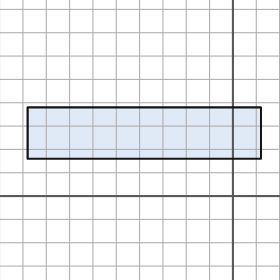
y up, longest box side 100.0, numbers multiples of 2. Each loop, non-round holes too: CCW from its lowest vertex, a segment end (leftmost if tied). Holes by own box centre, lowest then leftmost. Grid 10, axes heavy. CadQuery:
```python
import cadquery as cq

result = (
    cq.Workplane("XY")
    .moveTo(-88.0, 16.0)
    .lineTo(12.0, 16.0)
    .lineTo(12.0, 38.0)
    .lineTo(-88.0, 38.0)
    .close()
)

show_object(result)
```